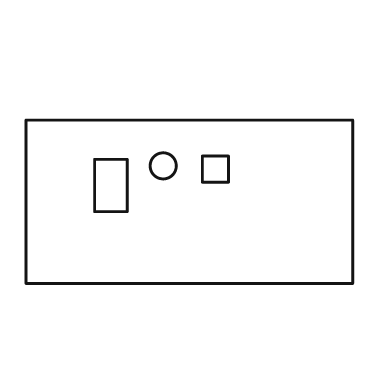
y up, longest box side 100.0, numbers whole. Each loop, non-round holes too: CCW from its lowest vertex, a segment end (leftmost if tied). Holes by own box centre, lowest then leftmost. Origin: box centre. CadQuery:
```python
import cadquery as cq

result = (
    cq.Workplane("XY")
    .moveTo(-50.0, -25.0)
    .lineTo(50.0, -25.0)
    .lineTo(50.0, 25.0)
    .lineTo(-50.0, 25.0)
    .close()
    .moveTo(-29.0, -3.0)
    .lineTo(-19.0, -3.0)
    .lineTo(-19.0, 13.0)
    .lineTo(-29.0, 13.0)
    .close()
    .moveTo(4.0, 6.0)
    .lineTo(12.0, 6.0)
    .lineTo(12.0, 14.0)
    .lineTo(4.0, 14.0)
    .close()
    .moveTo(-8.0, 11.0)
    .circle(4.0)
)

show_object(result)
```